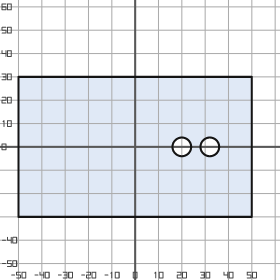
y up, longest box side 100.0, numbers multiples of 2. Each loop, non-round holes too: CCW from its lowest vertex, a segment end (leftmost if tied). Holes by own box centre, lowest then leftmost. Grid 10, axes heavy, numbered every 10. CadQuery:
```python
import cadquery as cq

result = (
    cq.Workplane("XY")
    .moveTo(-50.0, -30.0)
    .lineTo(50.0, -30.0)
    .lineTo(50.0, 30.0)
    .lineTo(-50.0, 30.0)
    .close()
    .moveTo(20.0, 0.0)
    .circle(4.0)
    .moveTo(32.0, 0.0)
    .circle(4.0)
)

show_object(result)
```